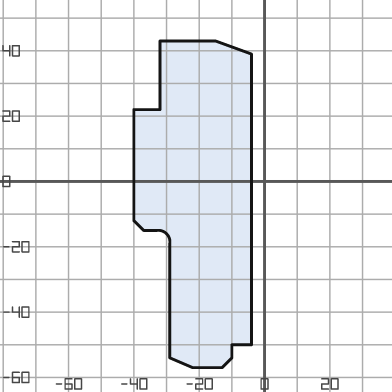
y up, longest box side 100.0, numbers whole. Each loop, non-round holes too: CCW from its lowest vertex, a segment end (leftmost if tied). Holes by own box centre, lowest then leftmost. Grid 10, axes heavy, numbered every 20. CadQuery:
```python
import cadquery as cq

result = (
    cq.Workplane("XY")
    .moveTo(-22.0, -57.0)
    .lineTo(-13.0, -57.0)
    .lineTo(-10.0, -54.0)
    .lineTo(-10.0, -50.0)
    .lineTo(-4.0, -50.0)
    .lineTo(-4.0, 39.0)
    .lineTo(-15.0, 43.0)
    .lineTo(-32.0, 43.0)
    .lineTo(-32.0, 22.0)
    .lineTo(-40.0, 22.0)
    .lineTo(-40.0, -12.0)
    .lineTo(-37.0, -15.0)
    .lineTo(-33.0, -15.0)
    .threePointArc((-30.0, -16.0), (-29.0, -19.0))
    .lineTo(-29.0, -54.0)
    .close()
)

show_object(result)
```